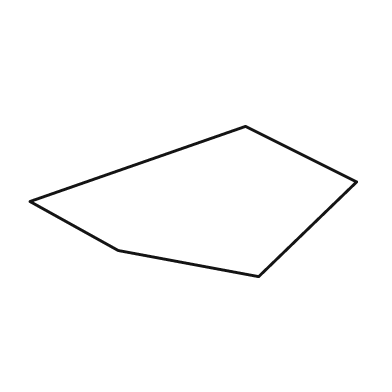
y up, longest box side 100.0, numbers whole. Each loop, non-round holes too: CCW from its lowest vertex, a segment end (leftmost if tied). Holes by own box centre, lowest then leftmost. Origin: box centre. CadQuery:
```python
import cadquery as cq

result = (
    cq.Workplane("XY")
    .moveTo(20.0, -23.0)
    .lineTo(50.0, 6.0)
    .lineTo(16.0, 23.0)
    .lineTo(-50.0, 0.0)
    .lineTo(-23.0, -15.0)
    .close()
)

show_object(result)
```